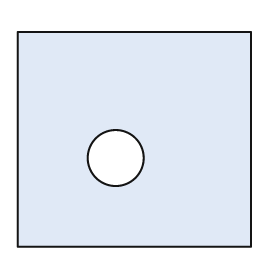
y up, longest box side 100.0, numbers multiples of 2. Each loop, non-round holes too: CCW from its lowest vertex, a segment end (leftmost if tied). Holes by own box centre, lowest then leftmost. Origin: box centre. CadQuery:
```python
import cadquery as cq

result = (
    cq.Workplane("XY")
    .moveTo(-50.0, -46.0)
    .lineTo(50.0, -46.0)
    .lineTo(50.0, 46.0)
    .lineTo(-50.0, 46.0)
    .close()
    .moveTo(-8.0, -8.0)
    .circle(12.0)
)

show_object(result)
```